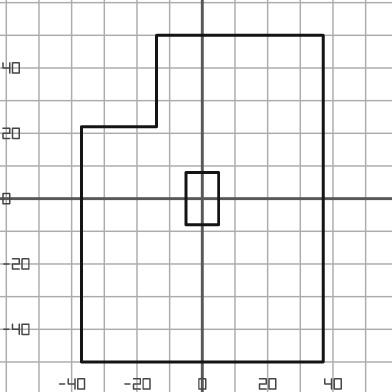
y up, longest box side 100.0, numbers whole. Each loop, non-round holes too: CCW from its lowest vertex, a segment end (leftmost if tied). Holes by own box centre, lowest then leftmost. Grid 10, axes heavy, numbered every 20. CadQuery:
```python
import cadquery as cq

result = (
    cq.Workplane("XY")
    .moveTo(-37.0, -50.0)
    .lineTo(37.0, -50.0)
    .lineTo(37.0, 50.0)
    .lineTo(-14.0, 50.0)
    .lineTo(-14.0, 22.0)
    .lineTo(-37.0, 22.0)
    .close()
    .moveTo(-5.0, -8.0)
    .lineTo(5.0, -8.0)
    .lineTo(5.0, 8.0)
    .lineTo(-5.0, 8.0)
    .close()
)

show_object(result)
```